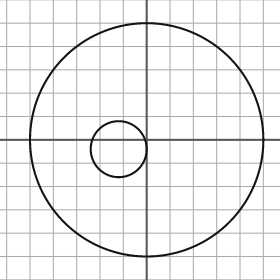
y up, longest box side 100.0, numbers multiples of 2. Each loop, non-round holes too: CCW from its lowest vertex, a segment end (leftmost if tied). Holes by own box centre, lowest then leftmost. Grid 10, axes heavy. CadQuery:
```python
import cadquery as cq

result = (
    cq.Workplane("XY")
    .moveTo(0.0, 0.0)
    .circle(50.0)
    .moveTo(-12.0, -4.0)
    .circle(12.0)
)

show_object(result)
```